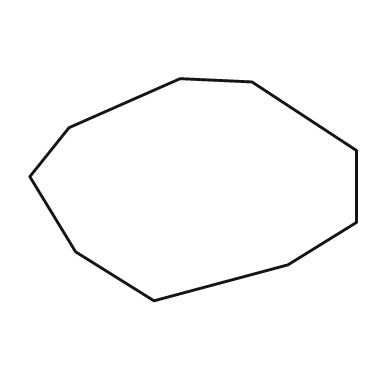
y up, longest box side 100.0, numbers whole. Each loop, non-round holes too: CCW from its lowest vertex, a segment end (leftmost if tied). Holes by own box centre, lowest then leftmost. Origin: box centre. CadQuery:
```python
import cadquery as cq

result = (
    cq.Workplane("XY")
    .moveTo(-12.0, -34.0)
    .lineTo(29.0, -23.0)
    .lineTo(50.0, -10.0)
    .lineTo(50.0, 12.0)
    .lineTo(18.0, 33.0)
    .lineTo(-4.0, 34.0)
    .lineTo(-38.0, 19.0)
    .lineTo(-50.0, 4.0)
    .lineTo(-36.0, -19.0)
    .close()
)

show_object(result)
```